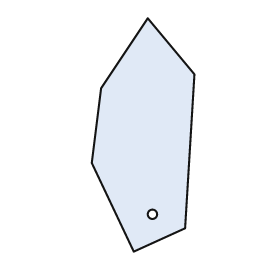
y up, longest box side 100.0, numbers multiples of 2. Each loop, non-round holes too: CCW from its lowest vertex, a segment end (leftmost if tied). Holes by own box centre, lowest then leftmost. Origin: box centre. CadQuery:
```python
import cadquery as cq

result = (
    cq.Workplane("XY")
    .moveTo(-4.0, -50.0)
    .lineTo(18.0, -40.0)
    .lineTo(22.0, 26.0)
    .lineTo(2.0, 50.0)
    .lineTo(-18.0, 20.0)
    .lineTo(-22.0, -12.0)
    .close()
    .moveTo(4.0, -34.0)
    .circle(2.0)
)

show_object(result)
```